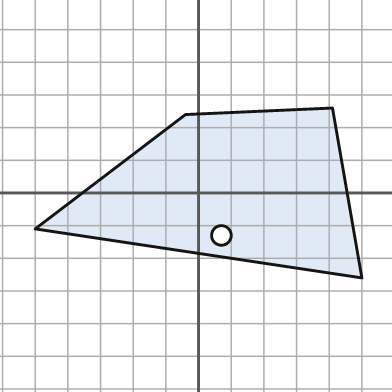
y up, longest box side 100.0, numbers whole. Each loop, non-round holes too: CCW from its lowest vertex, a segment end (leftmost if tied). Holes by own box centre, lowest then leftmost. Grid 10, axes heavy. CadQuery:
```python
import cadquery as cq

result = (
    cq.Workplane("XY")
    .moveTo(50.0, -26.0)
    .lineTo(41.0, 26.0)
    .lineTo(-4.0, 24.0)
    .lineTo(-50.0, -11.0)
    .close()
    .moveTo(7.0, -13.0)
    .circle(3.0)
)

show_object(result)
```